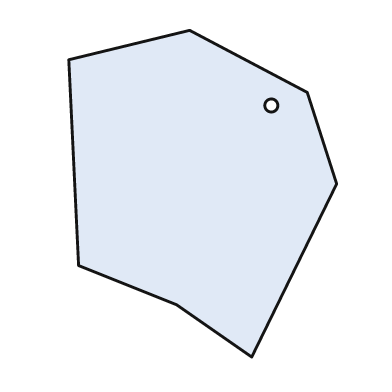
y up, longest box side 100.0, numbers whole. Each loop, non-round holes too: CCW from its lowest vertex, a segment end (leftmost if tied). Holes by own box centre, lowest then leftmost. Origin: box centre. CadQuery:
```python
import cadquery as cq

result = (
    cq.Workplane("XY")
    .moveTo(15.0, -50.0)
    .lineTo(41.0, 3.0)
    .lineTo(32.0, 31.0)
    .lineTo(-4.0, 50.0)
    .lineTo(-41.0, 41.0)
    .lineTo(-38.0, -22.0)
    .lineTo(-8.0, -34.0)
    .close()
    .moveTo(21.0, 27.0)
    .circle(2.0)
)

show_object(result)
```